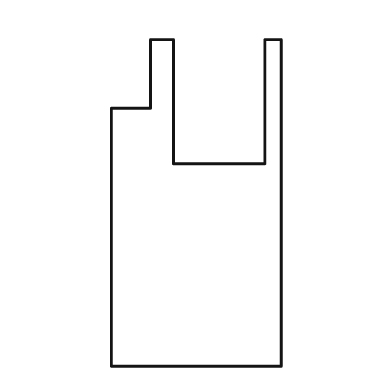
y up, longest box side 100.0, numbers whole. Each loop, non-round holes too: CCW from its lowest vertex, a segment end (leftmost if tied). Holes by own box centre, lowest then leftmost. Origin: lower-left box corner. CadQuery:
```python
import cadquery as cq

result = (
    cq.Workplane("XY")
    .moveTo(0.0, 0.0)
    .lineTo(52.0, 0.0)
    .lineTo(52.0, 100.0)
    .lineTo(47.0, 100.0)
    .lineTo(47.0, 62.0)
    .lineTo(19.0, 62.0)
    .lineTo(19.0, 100.0)
    .lineTo(12.0, 100.0)
    .lineTo(12.0, 79.0)
    .lineTo(0.0, 79.0)
    .close()
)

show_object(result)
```